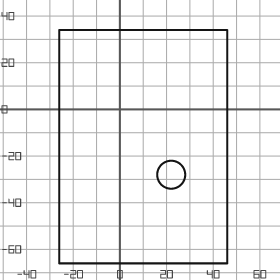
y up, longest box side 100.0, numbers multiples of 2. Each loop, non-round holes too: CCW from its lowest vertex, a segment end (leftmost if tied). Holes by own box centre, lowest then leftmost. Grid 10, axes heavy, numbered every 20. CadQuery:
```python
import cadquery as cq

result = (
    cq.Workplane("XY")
    .moveTo(-26.0, -66.0)
    .lineTo(46.0, -66.0)
    .lineTo(46.0, 34.0)
    .lineTo(-26.0, 34.0)
    .close()
    .moveTo(22.0, -28.0)
    .circle(6.0)
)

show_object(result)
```